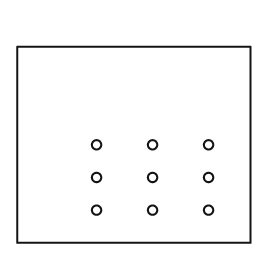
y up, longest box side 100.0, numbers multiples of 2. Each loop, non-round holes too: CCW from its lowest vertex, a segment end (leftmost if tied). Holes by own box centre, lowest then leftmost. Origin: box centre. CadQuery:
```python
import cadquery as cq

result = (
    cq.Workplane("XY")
    .moveTo(-50.0, -42.0)
    .lineTo(50.0, -42.0)
    .lineTo(50.0, 42.0)
    .lineTo(-50.0, 42.0)
    .close()
    .moveTo(-16.0, -28.0)
    .circle(2.0)
    .moveTo(8.0, -28.0)
    .circle(2.0)
    .moveTo(32.0, -28.0)
    .circle(2.0)
    .moveTo(-16.0, -14.0)
    .circle(2.0)
    .moveTo(8.0, -14.0)
    .circle(2.0)
    .moveTo(32.0, -14.0)
    .circle(2.0)
    .moveTo(-16.0, 0.0)
    .circle(2.0)
    .moveTo(8.0, 0.0)
    .circle(2.0)
    .moveTo(32.0, 0.0)
    .circle(2.0)
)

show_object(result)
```